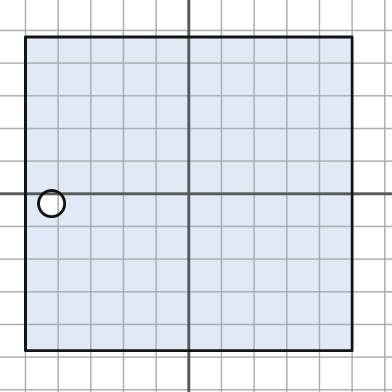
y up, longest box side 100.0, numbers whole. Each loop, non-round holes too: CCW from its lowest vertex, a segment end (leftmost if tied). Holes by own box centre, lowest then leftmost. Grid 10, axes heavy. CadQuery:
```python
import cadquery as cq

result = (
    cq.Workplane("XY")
    .moveTo(-50.0, -48.0)
    .lineTo(50.0, -48.0)
    .lineTo(50.0, 48.0)
    .lineTo(-50.0, 48.0)
    .close()
    .moveTo(-42.0, -3.0)
    .circle(4.0)
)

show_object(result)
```